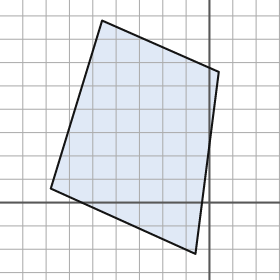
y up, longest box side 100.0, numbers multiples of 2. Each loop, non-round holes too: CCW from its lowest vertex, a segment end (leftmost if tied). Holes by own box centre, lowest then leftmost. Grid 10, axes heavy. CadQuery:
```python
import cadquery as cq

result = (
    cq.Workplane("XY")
    .moveTo(-6.0, -22.0)
    .lineTo(4.0, 56.0)
    .lineTo(-46.0, 78.0)
    .lineTo(-68.0, 6.0)
    .close()
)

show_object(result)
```